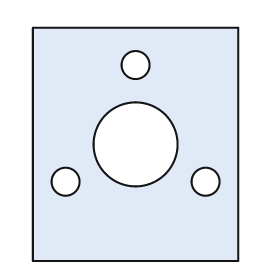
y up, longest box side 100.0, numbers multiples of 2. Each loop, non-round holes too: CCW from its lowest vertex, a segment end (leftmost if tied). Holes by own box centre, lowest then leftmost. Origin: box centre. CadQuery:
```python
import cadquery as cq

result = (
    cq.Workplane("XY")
    .moveTo(-44.0, -50.0)
    .lineTo(44.0, -50.0)
    .lineTo(44.0, 50.0)
    .lineTo(-44.0, 50.0)
    .close()
    .moveTo(-30.0, -16.0)
    .circle(6.0)
    .moveTo(30.0, -16.0)
    .circle(6.0)
    .moveTo(0.0, 0.0)
    .circle(18.0)
    .moveTo(0.0, 34.0)
    .circle(6.0)
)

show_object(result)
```